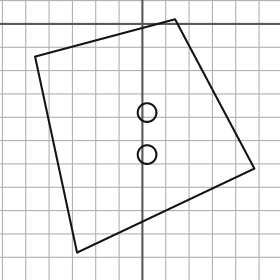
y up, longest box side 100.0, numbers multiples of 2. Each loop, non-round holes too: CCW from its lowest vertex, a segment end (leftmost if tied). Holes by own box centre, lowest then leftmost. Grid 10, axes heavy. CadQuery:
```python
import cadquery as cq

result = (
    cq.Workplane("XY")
    .moveTo(-28.0, -98.0)
    .lineTo(48.0, -62.0)
    .lineTo(14.0, 2.0)
    .lineTo(-46.0, -14.0)
    .close()
    .moveTo(2.0, -56.0)
    .circle(4.0)
    .moveTo(2.0, -38.0)
    .circle(4.0)
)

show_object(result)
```